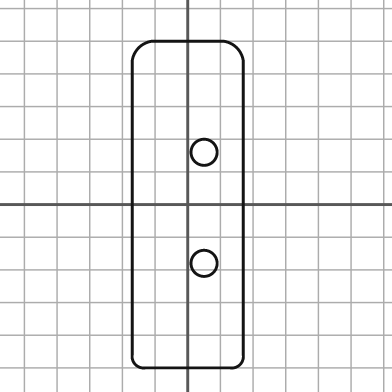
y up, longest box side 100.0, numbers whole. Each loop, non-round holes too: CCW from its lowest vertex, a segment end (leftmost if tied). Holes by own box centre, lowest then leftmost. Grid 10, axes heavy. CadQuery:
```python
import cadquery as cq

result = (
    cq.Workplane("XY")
    .moveTo(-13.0, -50.0)
    .lineTo(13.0, -50.0)
    .threePointArc((16.0, -49.0), (17.0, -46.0))
    .lineTo(17.0, 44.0)
    .threePointArc((15.0, 48.0), (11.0, 50.0))
    .lineTo(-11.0, 50.0)
    .threePointArc((-15.0, 48.0), (-17.0, 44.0))
    .lineTo(-17.0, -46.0)
    .threePointArc((-16.0, -49.0), (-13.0, -50.0))
    .close()
    .moveTo(5.0, -18.0)
    .circle(4.0)
    .moveTo(5.0, 16.0)
    .circle(4.0)
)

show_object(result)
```